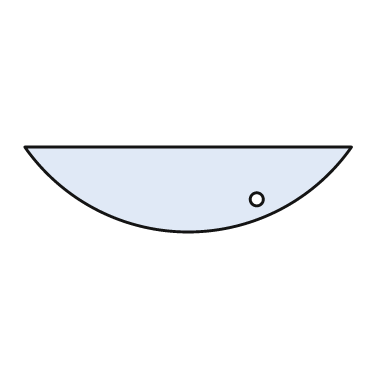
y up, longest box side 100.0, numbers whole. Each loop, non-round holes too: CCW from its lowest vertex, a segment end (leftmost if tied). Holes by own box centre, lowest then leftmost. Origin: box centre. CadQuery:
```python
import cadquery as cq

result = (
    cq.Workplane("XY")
    .moveTo(-50.0, 13.0)
    .threePointArc((0.0, -13.0), (50.0, 13.0))
    .close()
    .moveTo(21.0, -3.0)
    .circle(2.0)
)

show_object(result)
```